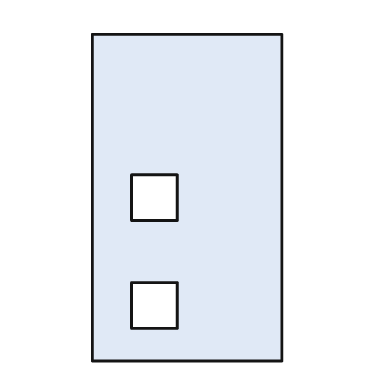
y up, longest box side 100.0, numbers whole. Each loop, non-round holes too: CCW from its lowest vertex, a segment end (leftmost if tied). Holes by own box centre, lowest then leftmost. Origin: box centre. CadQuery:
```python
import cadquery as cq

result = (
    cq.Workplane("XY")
    .moveTo(-29.0, -50.0)
    .lineTo(29.0, -50.0)
    .lineTo(29.0, 50.0)
    .lineTo(-29.0, 50.0)
    .close()
    .moveTo(-17.0, -40.0)
    .lineTo(-3.0, -40.0)
    .lineTo(-3.0, -26.0)
    .lineTo(-17.0, -26.0)
    .close()
    .moveTo(-17.0, -7.0)
    .lineTo(-3.0, -7.0)
    .lineTo(-3.0, 7.0)
    .lineTo(-17.0, 7.0)
    .close()
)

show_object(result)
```